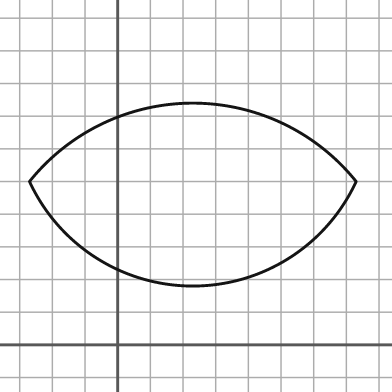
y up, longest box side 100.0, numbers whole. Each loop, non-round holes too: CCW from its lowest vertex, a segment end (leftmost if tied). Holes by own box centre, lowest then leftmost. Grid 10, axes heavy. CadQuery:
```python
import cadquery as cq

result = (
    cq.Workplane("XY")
    .moveTo(-27.0, 50.0)
    .threePointArc((23.0, 18.0), (73.0, 50.0))
    .threePointArc((23.0, 74.0), (-27.0, 50.0))
    .close()
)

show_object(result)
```